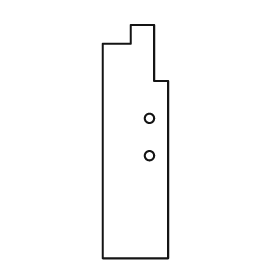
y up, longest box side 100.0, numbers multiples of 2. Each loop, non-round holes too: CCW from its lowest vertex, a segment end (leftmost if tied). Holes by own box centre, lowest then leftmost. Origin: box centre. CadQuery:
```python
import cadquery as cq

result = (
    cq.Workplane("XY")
    .moveTo(-14.0, -50.0)
    .lineTo(14.0, -50.0)
    .lineTo(14.0, 26.0)
    .lineTo(8.0, 26.0)
    .lineTo(8.0, 50.0)
    .lineTo(-2.0, 50.0)
    .lineTo(-2.0, 42.0)
    .lineTo(-14.0, 42.0)
    .close()
    .moveTo(6.0, -6.0)
    .circle(2.0)
    .moveTo(6.0, 10.0)
    .circle(2.0)
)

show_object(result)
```